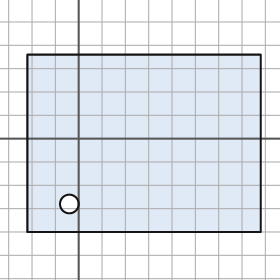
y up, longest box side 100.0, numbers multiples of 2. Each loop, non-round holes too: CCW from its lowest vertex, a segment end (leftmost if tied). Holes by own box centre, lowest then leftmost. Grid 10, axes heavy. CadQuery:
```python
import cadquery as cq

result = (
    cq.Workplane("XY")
    .moveTo(-22.0, -40.0)
    .lineTo(78.0, -40.0)
    .lineTo(78.0, 36.0)
    .lineTo(-22.0, 36.0)
    .close()
    .moveTo(-4.0, -28.0)
    .circle(4.0)
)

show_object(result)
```